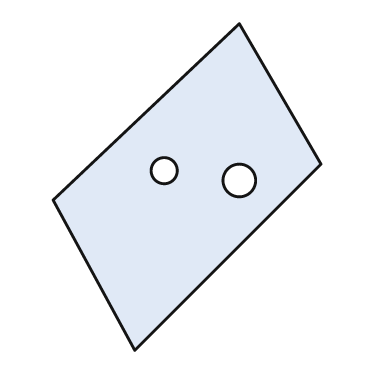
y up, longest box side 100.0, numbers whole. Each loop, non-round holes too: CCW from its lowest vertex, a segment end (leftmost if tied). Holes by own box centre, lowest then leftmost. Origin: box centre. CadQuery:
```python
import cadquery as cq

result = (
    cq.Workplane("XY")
    .moveTo(-16.0, -50.0)
    .lineTo(41.0, 7.0)
    .lineTo(16.0, 50.0)
    .lineTo(-41.0, -4.0)
    .close()
    .moveTo(16.0, 2.0)
    .circle(5.0)
    .moveTo(-7.0, 5.0)
    .circle(4.0)
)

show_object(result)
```